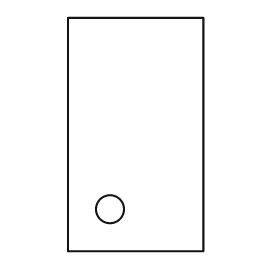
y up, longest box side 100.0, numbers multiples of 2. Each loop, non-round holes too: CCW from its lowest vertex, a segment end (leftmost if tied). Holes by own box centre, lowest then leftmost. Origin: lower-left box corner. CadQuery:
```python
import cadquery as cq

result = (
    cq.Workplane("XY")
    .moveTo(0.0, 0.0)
    .lineTo(58.0, 0.0)
    .lineTo(58.0, 100.0)
    .lineTo(0.0, 100.0)
    .close()
    .moveTo(18.0, 18.0)
    .circle(6.0)
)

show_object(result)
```